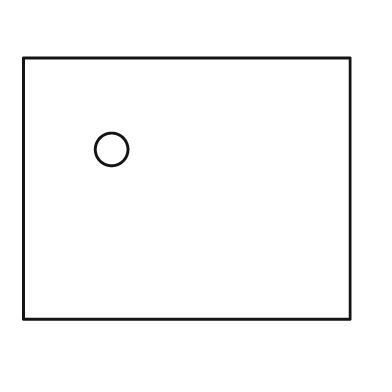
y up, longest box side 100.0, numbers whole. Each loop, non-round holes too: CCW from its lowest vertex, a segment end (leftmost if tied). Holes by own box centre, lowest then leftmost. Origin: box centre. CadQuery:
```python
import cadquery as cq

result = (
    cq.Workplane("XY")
    .moveTo(-50.0, -40.0)
    .lineTo(50.0, -40.0)
    .lineTo(50.0, 40.0)
    .lineTo(-50.0, 40.0)
    .close()
    .moveTo(-23.0, 12.0)
    .circle(5.0)
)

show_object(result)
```